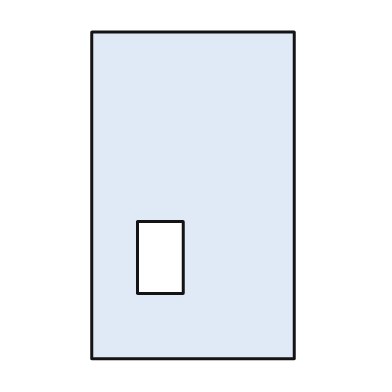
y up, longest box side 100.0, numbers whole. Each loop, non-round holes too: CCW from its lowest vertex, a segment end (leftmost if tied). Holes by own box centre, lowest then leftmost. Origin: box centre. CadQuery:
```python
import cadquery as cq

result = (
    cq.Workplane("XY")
    .moveTo(-31.0, -50.0)
    .lineTo(31.0, -50.0)
    .lineTo(31.0, 50.0)
    .lineTo(-31.0, 50.0)
    .close()
    .moveTo(-17.0, -30.0)
    .lineTo(-3.0, -30.0)
    .lineTo(-3.0, -8.0)
    .lineTo(-17.0, -8.0)
    .close()
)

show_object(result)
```